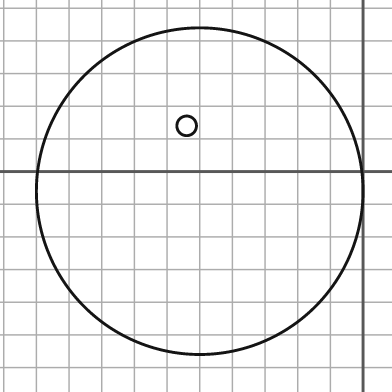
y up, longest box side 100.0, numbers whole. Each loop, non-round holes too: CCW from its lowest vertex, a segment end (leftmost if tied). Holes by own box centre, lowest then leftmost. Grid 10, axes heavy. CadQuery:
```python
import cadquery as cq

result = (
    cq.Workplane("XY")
    .moveTo(-50.0, -6.0)
    .circle(50.0)
    .moveTo(-54.0, 14.0)
    .circle(3.0)
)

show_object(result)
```